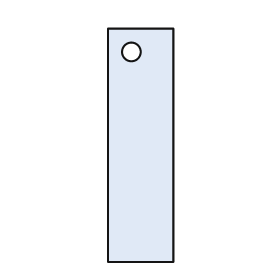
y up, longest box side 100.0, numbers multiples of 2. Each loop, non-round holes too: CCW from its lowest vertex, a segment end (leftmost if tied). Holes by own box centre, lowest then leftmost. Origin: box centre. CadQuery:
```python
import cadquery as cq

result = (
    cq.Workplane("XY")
    .moveTo(-14.0, -50.0)
    .lineTo(14.0, -50.0)
    .lineTo(14.0, 50.0)
    .lineTo(-14.0, 50.0)
    .close()
    .moveTo(-4.0, 40.0)
    .circle(4.0)
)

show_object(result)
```